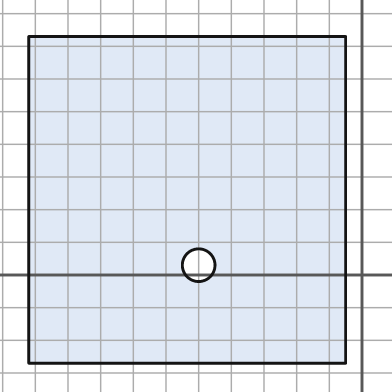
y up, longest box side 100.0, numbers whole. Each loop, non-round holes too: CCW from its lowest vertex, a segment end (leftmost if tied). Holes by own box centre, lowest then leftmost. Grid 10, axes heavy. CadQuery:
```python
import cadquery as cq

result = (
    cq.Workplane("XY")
    .moveTo(-102.0, -27.0)
    .lineTo(-5.0, -27.0)
    .lineTo(-5.0, 73.0)
    .lineTo(-102.0, 73.0)
    .close()
    .moveTo(-50.0, 3.0)
    .circle(5.0)
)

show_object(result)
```